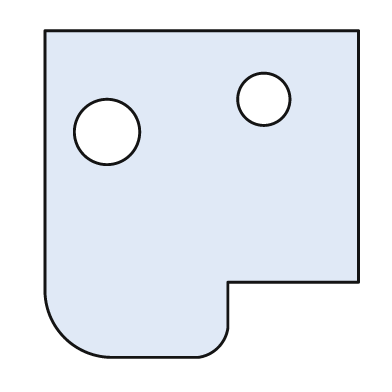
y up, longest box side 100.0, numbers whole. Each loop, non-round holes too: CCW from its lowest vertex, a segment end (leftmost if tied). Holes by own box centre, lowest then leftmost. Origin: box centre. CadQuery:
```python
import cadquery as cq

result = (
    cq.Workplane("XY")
    .moveTo(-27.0, -50.0)
    .lineTo(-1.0, -50.0)
    .threePointArc((5.0, -47.0), (8.0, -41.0))
    .lineTo(8.0, -27.0)
    .lineTo(48.0, -27.0)
    .lineTo(48.0, 50.0)
    .lineTo(-48.0, 50.0)
    .lineTo(-48.0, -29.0)
    .threePointArc((-42.0, -44.0), (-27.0, -50.0))
    .close()
    .moveTo(-29.0, 19.0)
    .circle(10.0)
    .moveTo(19.0, 29.0)
    .circle(8.0)
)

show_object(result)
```